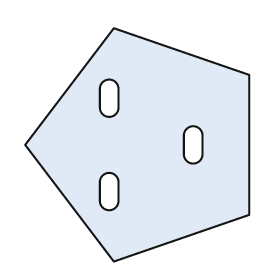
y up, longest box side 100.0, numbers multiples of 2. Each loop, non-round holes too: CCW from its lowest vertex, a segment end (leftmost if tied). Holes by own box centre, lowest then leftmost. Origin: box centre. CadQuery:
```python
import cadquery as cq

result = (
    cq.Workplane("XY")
    .moveTo(-10.0, -50.0)
    .lineTo(48.0, -30.0)
    .lineTo(48.0, 30.0)
    .lineTo(-10.0, 50.0)
    .lineTo(-48.0, 0.0)
    .close()
    .moveTo(-16.0, -24.0)
    .threePointArc((-12.0, -28.0), (-8.0, -24.0))
    .lineTo(-8.0, -16.0)
    .threePointArc((-12.0, -12.0), (-16.0, -16.0))
    .close()
    .moveTo(20.0, -4.0)
    .threePointArc((24.0, -8.0), (28.0, -4.0))
    .lineTo(28.0, 4.0)
    .threePointArc((24.0, 8.0), (20.0, 4.0))
    .close()
    .moveTo(-16.0, 16.0)
    .threePointArc((-12.0, 12.0), (-8.0, 16.0))
    .lineTo(-8.0, 24.0)
    .threePointArc((-12.0, 28.0), (-16.0, 24.0))
    .close()
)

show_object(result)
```